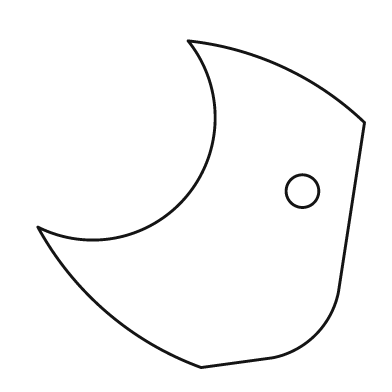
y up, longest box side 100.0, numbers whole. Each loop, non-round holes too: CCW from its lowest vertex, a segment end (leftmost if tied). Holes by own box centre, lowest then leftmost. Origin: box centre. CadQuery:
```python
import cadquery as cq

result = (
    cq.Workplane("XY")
    .moveTo(0.0, -50.0)
    .lineTo(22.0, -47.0)
    .threePointArc((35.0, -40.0), (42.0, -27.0))
    .lineTo(50.0, 25.0)
    .threePointArc((25.0, 42.0), (-4.0, 50.0))
    .threePointArc((-4.0, 3.0), (-50.0, -7.0))
    .threePointArc((-29.0, -33.0), (0.0, -50.0))
    .close()
    .moveTo(31.0, 4.0)
    .circle(5.0)
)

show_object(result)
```